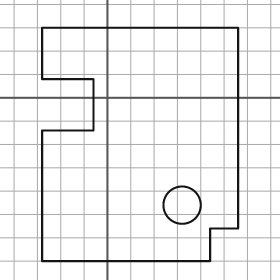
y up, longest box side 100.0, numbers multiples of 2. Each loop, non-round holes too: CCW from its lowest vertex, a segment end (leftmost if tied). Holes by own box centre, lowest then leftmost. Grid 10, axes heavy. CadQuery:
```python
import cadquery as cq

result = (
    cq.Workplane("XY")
    .moveTo(-28.0, -70.0)
    .lineTo(44.0, -70.0)
    .lineTo(44.0, -56.0)
    .lineTo(56.0, -56.0)
    .lineTo(56.0, 30.0)
    .lineTo(-28.0, 30.0)
    .lineTo(-28.0, 8.0)
    .lineTo(-6.0, 8.0)
    .lineTo(-6.0, -14.0)
    .lineTo(-28.0, -14.0)
    .close()
    .moveTo(32.0, -46.0)
    .circle(8.0)
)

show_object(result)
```